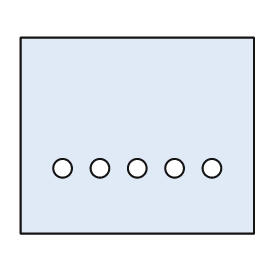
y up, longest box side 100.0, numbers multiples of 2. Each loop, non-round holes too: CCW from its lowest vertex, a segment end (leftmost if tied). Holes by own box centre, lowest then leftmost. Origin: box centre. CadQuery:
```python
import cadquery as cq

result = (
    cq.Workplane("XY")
    .moveTo(-50.0, -42.0)
    .lineTo(50.0, -42.0)
    .lineTo(50.0, 42.0)
    .lineTo(-50.0, 42.0)
    .close()
    .moveTo(-32.0, -14.0)
    .circle(4.0)
    .moveTo(-16.0, -14.0)
    .circle(4.0)
    .moveTo(0.0, -14.0)
    .circle(4.0)
    .moveTo(16.0, -14.0)
    .circle(4.0)
    .moveTo(32.0, -14.0)
    .circle(4.0)
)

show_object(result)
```